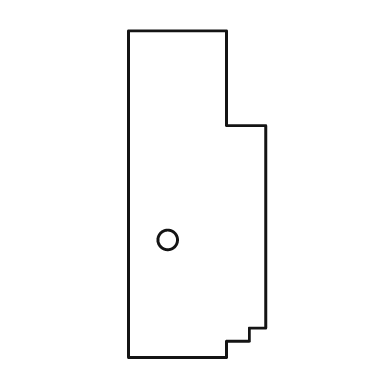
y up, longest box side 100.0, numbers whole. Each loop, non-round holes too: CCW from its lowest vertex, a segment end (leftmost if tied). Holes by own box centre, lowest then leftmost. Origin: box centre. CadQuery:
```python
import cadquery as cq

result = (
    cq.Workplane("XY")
    .moveTo(-21.0, -50.0)
    .lineTo(9.0, -50.0)
    .lineTo(9.0, -45.0)
    .lineTo(16.0, -45.0)
    .lineTo(16.0, -41.0)
    .lineTo(21.0, -41.0)
    .lineTo(21.0, 21.0)
    .lineTo(9.0, 21.0)
    .lineTo(9.0, 50.0)
    .lineTo(-21.0, 50.0)
    .close()
    .moveTo(-9.0, -14.0)
    .circle(3.0)
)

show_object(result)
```